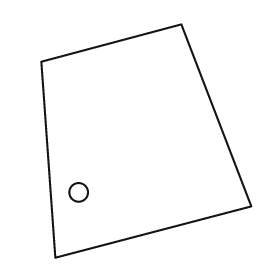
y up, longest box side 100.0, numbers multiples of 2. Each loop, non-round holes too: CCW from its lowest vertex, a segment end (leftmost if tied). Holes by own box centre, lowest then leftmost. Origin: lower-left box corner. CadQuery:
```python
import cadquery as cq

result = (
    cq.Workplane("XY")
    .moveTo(6.0, 0.0)
    .lineTo(90.0, 22.0)
    .lineTo(60.0, 100.0)
    .lineTo(0.0, 84.0)
    .close()
    .moveTo(16.0, 28.0)
    .circle(4.0)
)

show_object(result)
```